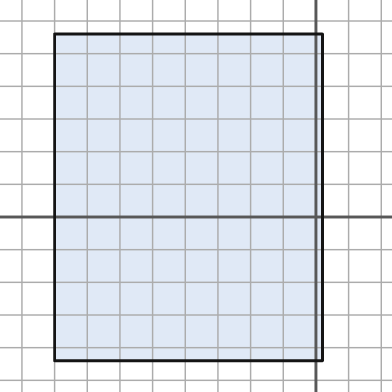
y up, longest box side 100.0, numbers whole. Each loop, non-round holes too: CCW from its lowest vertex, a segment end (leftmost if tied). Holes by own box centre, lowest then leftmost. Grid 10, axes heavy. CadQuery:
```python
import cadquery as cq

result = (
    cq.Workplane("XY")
    .moveTo(-80.0, -44.0)
    .lineTo(2.0, -44.0)
    .lineTo(2.0, 56.0)
    .lineTo(-80.0, 56.0)
    .close()
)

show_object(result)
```